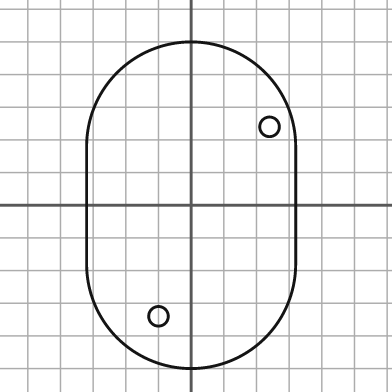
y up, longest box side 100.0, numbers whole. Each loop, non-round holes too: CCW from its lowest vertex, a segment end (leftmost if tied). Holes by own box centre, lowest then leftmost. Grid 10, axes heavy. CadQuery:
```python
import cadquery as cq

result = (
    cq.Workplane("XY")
    .moveTo(-32.0, -18.0)
    .threePointArc((0.0, -50.0), (32.0, -18.0))
    .lineTo(32.0, 18.0)
    .threePointArc((0.0, 50.0), (-32.0, 18.0))
    .close()
    .moveTo(-10.0, -34.0)
    .circle(3.0)
    .moveTo(24.0, 24.0)
    .circle(3.0)
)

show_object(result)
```